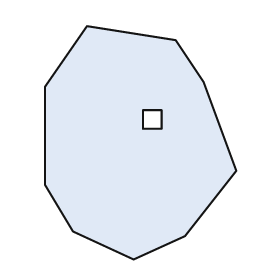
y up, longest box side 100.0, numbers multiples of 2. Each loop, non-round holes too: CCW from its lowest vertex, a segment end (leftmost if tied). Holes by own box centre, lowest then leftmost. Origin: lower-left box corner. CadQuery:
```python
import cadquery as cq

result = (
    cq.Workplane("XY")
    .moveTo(38.0, 0.0)
    .lineTo(60.0, 10.0)
    .lineTo(82.0, 38.0)
    .lineTo(68.0, 76.0)
    .lineTo(56.0, 94.0)
    .lineTo(18.0, 100.0)
    .lineTo(0.0, 74.0)
    .lineTo(0.0, 32.0)
    .lineTo(12.0, 12.0)
    .close()
    .moveTo(42.0, 56.0)
    .lineTo(50.0, 56.0)
    .lineTo(50.0, 64.0)
    .lineTo(42.0, 64.0)
    .close()
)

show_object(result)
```